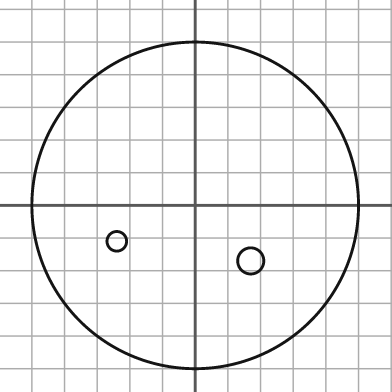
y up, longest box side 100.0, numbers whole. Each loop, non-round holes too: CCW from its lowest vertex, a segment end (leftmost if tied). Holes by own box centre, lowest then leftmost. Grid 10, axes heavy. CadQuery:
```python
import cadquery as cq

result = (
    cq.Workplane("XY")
    .moveTo(0.0, 0.0)
    .circle(50.0)
    .moveTo(17.0, -17.0)
    .circle(4.0)
    .moveTo(-24.0, -11.0)
    .circle(3.0)
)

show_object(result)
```